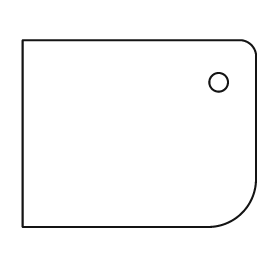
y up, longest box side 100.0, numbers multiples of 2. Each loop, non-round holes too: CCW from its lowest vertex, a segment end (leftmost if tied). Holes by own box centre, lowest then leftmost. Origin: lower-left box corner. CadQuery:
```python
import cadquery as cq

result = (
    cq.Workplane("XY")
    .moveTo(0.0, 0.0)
    .lineTo(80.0, 0.0)
    .threePointArc((94.0, 6.0), (100.0, 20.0))
    .lineTo(100.0, 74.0)
    .threePointArc((98.0, 78.0), (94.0, 80.0))
    .lineTo(0.0, 80.0)
    .close()
    .moveTo(84.0, 62.0)
    .circle(4.0)
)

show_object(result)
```